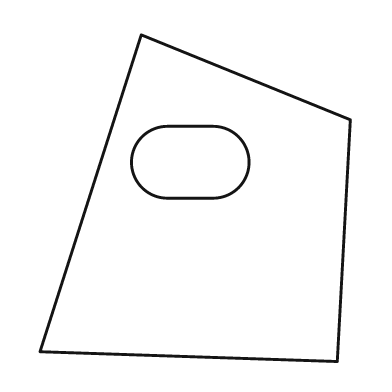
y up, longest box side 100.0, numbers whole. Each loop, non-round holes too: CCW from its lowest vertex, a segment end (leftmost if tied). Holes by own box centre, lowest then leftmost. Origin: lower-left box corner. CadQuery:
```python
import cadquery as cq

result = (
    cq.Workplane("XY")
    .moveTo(91.0, 0.0)
    .lineTo(95.0, 74.0)
    .lineTo(31.0, 100.0)
    .lineTo(0.0, 3.0)
    .close()
    .moveTo(39.0, 50.0)
    .lineTo(53.0, 50.0)
    .threePointArc((64.0, 61.0), (53.0, 72.0))
    .lineTo(39.0, 72.0)
    .threePointArc((28.0, 61.0), (39.0, 50.0))
    .close()
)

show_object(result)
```